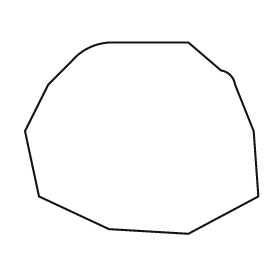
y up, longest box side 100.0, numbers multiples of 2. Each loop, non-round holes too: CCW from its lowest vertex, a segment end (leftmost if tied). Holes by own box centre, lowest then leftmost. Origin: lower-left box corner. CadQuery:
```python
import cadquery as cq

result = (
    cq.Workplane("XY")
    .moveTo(70.0, 0.0)
    .lineTo(100.0, 16.0)
    .lineTo(98.0, 44.0)
    .lineTo(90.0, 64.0)
    .threePointArc((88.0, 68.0), (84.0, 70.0))
    .lineTo(70.0, 82.0)
    .lineTo(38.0, 82.0)
    .threePointArc((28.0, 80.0), (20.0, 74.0))
    .lineTo(10.0, 64.0)
    .lineTo(0.0, 44.0)
    .lineTo(6.0, 16.0)
    .lineTo(36.0, 2.0)
    .close()
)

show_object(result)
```